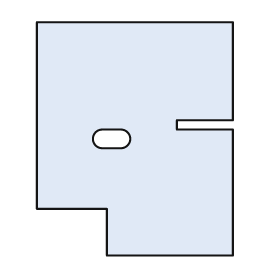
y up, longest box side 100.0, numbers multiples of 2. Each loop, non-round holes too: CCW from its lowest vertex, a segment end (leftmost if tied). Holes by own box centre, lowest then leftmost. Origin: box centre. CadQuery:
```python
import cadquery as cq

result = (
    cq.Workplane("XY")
    .moveTo(-12.0, -50.0)
    .lineTo(42.0, -50.0)
    .lineTo(42.0, 4.0)
    .lineTo(18.0, 4.0)
    .lineTo(18.0, 8.0)
    .lineTo(42.0, 8.0)
    .lineTo(42.0, 50.0)
    .lineTo(-42.0, 50.0)
    .lineTo(-42.0, -30.0)
    .lineTo(-12.0, -30.0)
    .close()
    .moveTo(-14.0, -4.0)
    .lineTo(-6.0, -4.0)
    .threePointArc((-2.0, 0.0), (-6.0, 4.0))
    .lineTo(-14.0, 4.0)
    .threePointArc((-18.0, 0.0), (-14.0, -4.0))
    .close()
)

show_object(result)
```